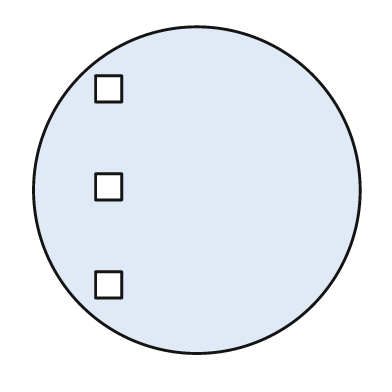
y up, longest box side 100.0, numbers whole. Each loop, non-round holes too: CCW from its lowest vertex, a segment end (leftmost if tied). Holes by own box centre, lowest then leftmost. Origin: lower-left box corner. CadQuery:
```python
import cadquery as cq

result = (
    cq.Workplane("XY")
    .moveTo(50.0, 50.0)
    .circle(50.0)
    .moveTo(19.0, 17.0)
    .lineTo(27.0, 17.0)
    .lineTo(27.0, 25.0)
    .lineTo(19.0, 25.0)
    .close()
    .moveTo(19.0, 47.0)
    .lineTo(27.0, 47.0)
    .lineTo(27.0, 55.0)
    .lineTo(19.0, 55.0)
    .close()
    .moveTo(19.0, 77.0)
    .lineTo(27.0, 77.0)
    .lineTo(27.0, 85.0)
    .lineTo(19.0, 85.0)
    .close()
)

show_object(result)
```